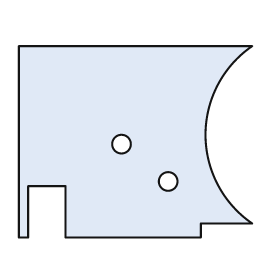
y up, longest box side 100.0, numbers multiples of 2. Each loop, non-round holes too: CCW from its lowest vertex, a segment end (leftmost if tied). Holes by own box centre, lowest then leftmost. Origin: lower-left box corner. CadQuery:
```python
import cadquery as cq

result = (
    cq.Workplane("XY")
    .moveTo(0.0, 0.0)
    .lineTo(4.0, 0.0)
    .lineTo(4.0, 22.0)
    .lineTo(20.0, 22.0)
    .lineTo(20.0, 0.0)
    .lineTo(78.0, 0.0)
    .lineTo(78.0, 6.0)
    .lineTo(100.0, 6.0)
    .threePointArc((80.0, 44.0), (100.0, 82.0))
    .lineTo(0.0, 82.0)
    .close()
    .moveTo(64.0, 24.0)
    .circle(4.0)
    .moveTo(44.0, 40.0)
    .circle(4.0)
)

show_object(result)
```